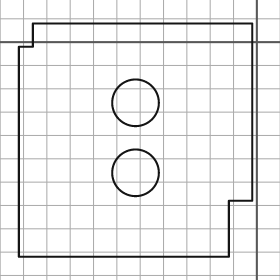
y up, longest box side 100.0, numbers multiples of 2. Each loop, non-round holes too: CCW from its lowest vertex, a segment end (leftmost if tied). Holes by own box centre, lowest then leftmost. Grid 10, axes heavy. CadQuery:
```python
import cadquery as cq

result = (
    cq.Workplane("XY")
    .moveTo(-102.0, -92.0)
    .lineTo(-12.0, -92.0)
    .lineTo(-12.0, -68.0)
    .lineTo(-2.0, -68.0)
    .lineTo(-2.0, 8.0)
    .lineTo(-96.0, 8.0)
    .lineTo(-96.0, -2.0)
    .lineTo(-102.0, -2.0)
    .close()
    .moveTo(-52.0, -56.0)
    .circle(10.0)
    .moveTo(-52.0, -26.0)
    .circle(10.0)
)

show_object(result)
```